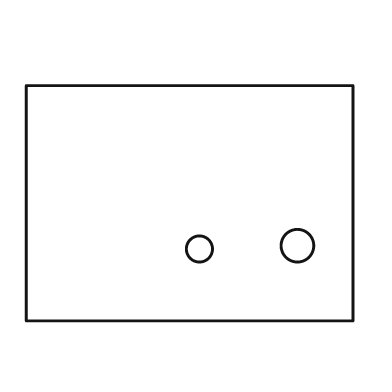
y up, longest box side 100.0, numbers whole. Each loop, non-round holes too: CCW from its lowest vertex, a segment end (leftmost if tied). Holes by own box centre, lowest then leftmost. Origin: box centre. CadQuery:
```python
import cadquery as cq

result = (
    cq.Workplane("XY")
    .moveTo(-50.0, -36.0)
    .lineTo(50.0, -36.0)
    .lineTo(50.0, 36.0)
    .lineTo(-50.0, 36.0)
    .close()
    .moveTo(3.0, -14.0)
    .circle(4.0)
    .moveTo(33.0, -13.0)
    .circle(5.0)
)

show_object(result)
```